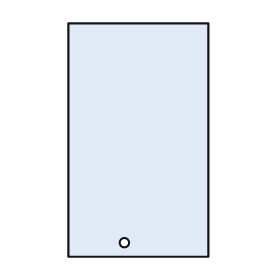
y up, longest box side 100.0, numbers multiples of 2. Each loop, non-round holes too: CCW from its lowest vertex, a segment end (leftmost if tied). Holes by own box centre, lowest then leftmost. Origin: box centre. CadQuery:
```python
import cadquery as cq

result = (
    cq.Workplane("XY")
    .moveTo(-30.0, -50.0)
    .lineTo(30.0, -50.0)
    .lineTo(30.0, 50.0)
    .lineTo(-30.0, 50.0)
    .close()
    .moveTo(-6.0, -44.0)
    .circle(2.0)
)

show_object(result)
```